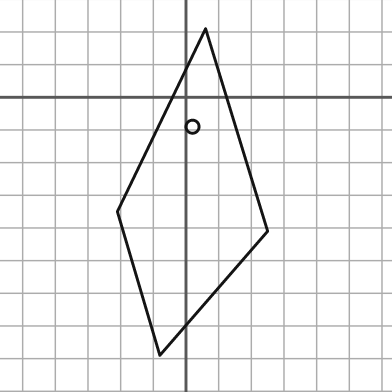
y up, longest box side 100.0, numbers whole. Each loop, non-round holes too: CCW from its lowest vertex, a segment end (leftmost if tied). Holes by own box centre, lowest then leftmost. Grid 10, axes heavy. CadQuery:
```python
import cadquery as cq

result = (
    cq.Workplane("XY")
    .moveTo(-8.0, -79.0)
    .lineTo(25.0, -41.0)
    .lineTo(6.0, 21.0)
    .lineTo(-21.0, -35.0)
    .close()
    .moveTo(2.0, -9.0)
    .circle(2.0)
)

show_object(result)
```